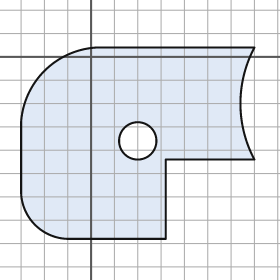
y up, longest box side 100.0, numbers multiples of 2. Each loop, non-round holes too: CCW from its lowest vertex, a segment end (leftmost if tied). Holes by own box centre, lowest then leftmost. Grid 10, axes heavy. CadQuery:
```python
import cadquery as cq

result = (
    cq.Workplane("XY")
    .moveTo(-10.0, -78.0)
    .lineTo(32.0, -78.0)
    .lineTo(32.0, -44.0)
    .lineTo(70.0, -44.0)
    .threePointArc((64.0, -20.0), (70.0, 4.0))
    .lineTo(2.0, 4.0)
    .threePointArc((-20.0, -6.0), (-30.0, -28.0))
    .lineTo(-30.0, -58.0)
    .threePointArc((-24.0, -72.0), (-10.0, -78.0))
    .close()
    .moveTo(20.0, -36.0)
    .circle(8.0)
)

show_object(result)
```